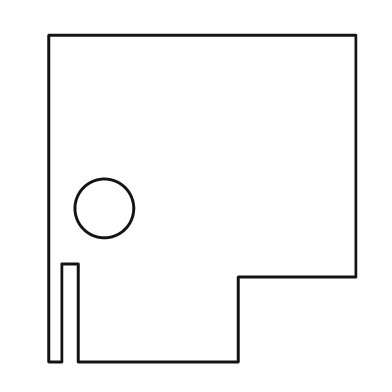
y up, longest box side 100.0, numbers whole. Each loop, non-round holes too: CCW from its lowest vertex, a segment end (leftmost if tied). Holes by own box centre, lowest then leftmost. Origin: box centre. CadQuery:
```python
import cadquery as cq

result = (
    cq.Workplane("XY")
    .moveTo(-47.0, -50.0)
    .lineTo(-43.0, -50.0)
    .lineTo(-43.0, -20.0)
    .lineTo(-38.0, -20.0)
    .lineTo(-38.0, -50.0)
    .lineTo(11.0, -50.0)
    .lineTo(11.0, -24.0)
    .lineTo(47.0, -24.0)
    .lineTo(47.0, 50.0)
    .lineTo(-47.0, 50.0)
    .close()
    .moveTo(-30.0, -3.0)
    .circle(9.0)
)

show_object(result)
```